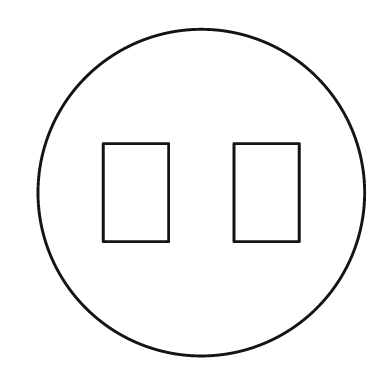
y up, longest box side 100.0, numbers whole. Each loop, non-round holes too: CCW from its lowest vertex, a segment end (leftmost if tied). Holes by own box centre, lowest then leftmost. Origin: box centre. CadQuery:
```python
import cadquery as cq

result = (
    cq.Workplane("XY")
    .moveTo(0.0, 0.0)
    .circle(50.0)
    .moveTo(-30.0, -15.0)
    .lineTo(-10.0, -15.0)
    .lineTo(-10.0, 15.0)
    .lineTo(-30.0, 15.0)
    .close()
    .moveTo(10.0, -15.0)
    .lineTo(30.0, -15.0)
    .lineTo(30.0, 15.0)
    .lineTo(10.0, 15.0)
    .close()
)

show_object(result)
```